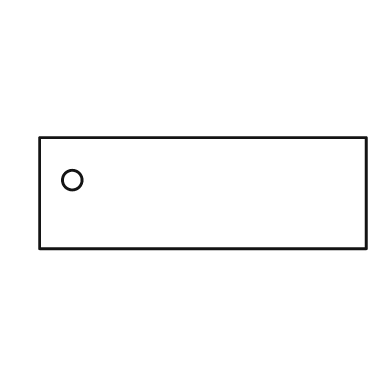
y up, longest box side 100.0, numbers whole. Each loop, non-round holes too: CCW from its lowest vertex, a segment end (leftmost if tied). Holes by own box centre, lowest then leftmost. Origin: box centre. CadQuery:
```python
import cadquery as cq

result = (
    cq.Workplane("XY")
    .moveTo(-50.0, -17.0)
    .lineTo(50.0, -17.0)
    .lineTo(50.0, 17.0)
    .lineTo(-50.0, 17.0)
    .close()
    .moveTo(-40.0, 4.0)
    .circle(3.0)
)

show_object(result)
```